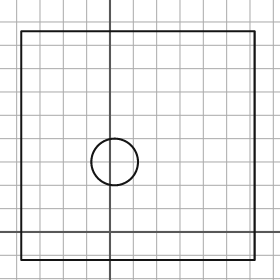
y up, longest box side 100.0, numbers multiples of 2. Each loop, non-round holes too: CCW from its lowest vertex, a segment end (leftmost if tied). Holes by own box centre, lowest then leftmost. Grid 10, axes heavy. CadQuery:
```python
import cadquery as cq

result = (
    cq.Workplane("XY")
    .moveTo(-38.0, -12.0)
    .lineTo(62.0, -12.0)
    .lineTo(62.0, 86.0)
    .lineTo(-38.0, 86.0)
    .close()
    .moveTo(2.0, 30.0)
    .circle(10.0)
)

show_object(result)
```